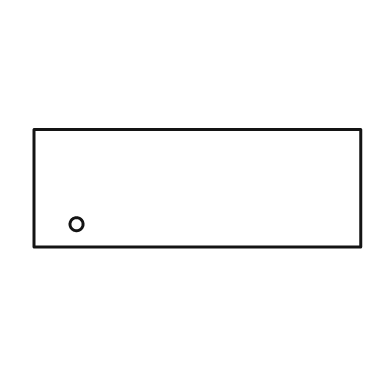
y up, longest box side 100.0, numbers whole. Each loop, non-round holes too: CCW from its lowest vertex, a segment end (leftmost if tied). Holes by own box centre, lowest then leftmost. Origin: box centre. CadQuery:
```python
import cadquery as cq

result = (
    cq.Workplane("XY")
    .moveTo(-50.0, -18.0)
    .lineTo(50.0, -18.0)
    .lineTo(50.0, 18.0)
    .lineTo(-50.0, 18.0)
    .close()
    .moveTo(-37.0, -11.0)
    .circle(2.0)
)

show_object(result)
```